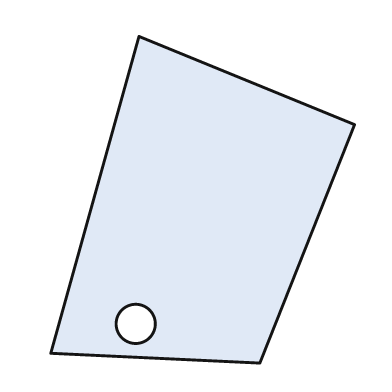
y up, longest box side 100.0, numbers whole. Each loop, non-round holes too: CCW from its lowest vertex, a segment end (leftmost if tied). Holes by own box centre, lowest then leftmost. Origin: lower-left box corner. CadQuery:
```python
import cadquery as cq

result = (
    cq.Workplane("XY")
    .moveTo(64.0, 0.0)
    .lineTo(93.0, 73.0)
    .lineTo(27.0, 100.0)
    .lineTo(0.0, 3.0)
    .close()
    .moveTo(26.0, 12.0)
    .circle(6.0)
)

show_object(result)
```